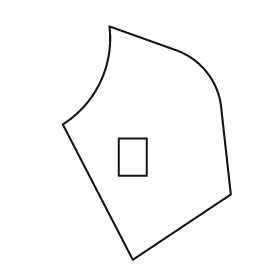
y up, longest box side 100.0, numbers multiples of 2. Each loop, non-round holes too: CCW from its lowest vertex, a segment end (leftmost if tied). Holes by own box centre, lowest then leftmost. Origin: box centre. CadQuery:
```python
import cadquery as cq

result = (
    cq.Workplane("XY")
    .moveTo(-6.0, -50.0)
    .lineTo(36.0, -22.0)
    .lineTo(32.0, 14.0)
    .threePointArc((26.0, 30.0), (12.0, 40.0))
    .lineTo(-16.0, 50.0)
    .threePointArc((-20.0, 26.0), (-36.0, 8.0))
    .close()
    .moveTo(-12.0, -14.0)
    .lineTo(0.0, -14.0)
    .lineTo(0.0, 2.0)
    .lineTo(-12.0, 2.0)
    .close()
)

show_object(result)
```